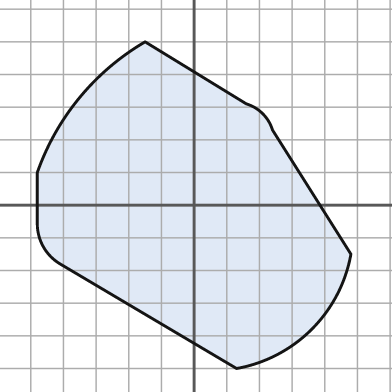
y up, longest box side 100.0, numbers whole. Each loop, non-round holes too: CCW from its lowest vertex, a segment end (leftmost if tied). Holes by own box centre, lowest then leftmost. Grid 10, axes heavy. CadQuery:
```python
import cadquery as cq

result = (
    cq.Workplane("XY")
    .moveTo(13.0, -50.0)
    .threePointArc((36.0, -38.0), (48.0, -15.0))
    .lineTo(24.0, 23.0)
    .threePointArc((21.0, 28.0), (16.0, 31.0))
    .lineTo(-15.0, 50.0)
    .threePointArc((-35.0, 33.0), (-48.0, 10.0))
    .lineTo(-48.0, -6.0)
    .threePointArc((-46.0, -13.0), (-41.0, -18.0))
    .close()
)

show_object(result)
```